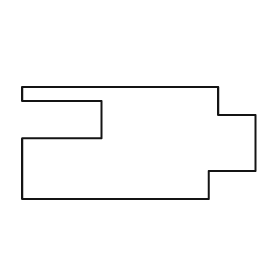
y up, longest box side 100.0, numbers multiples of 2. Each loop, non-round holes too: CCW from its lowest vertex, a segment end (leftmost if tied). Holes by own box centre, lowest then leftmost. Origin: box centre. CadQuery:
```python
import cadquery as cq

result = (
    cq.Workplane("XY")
    .moveTo(-50.0, -24.0)
    .lineTo(30.0, -24.0)
    .lineTo(30.0, -12.0)
    .lineTo(50.0, -12.0)
    .lineTo(50.0, 12.0)
    .lineTo(34.0, 12.0)
    .lineTo(34.0, 24.0)
    .lineTo(-50.0, 24.0)
    .lineTo(-50.0, 18.0)
    .lineTo(-16.0, 18.0)
    .lineTo(-16.0, 2.0)
    .lineTo(-50.0, 2.0)
    .close()
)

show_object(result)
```